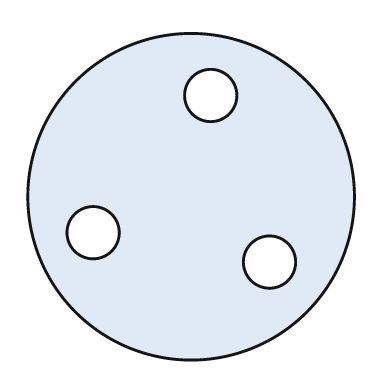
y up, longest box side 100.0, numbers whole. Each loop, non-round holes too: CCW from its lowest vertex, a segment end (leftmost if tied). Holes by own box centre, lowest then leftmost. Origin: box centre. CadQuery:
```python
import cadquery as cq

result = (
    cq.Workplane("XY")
    .moveTo(0.0, 0.0)
    .circle(50.0)
    .moveTo(24.0, -20.0)
    .circle(8.0)
    .moveTo(-30.0, -11.0)
    .circle(8.0)
    .moveTo(6.0, 31.0)
    .circle(8.0)
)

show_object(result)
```